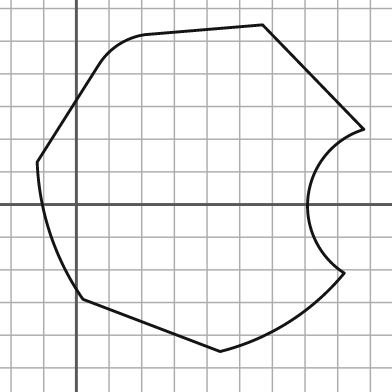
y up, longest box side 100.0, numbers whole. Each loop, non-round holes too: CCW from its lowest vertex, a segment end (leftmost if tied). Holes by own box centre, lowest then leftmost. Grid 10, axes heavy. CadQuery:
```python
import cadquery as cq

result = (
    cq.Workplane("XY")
    .moveTo(44.0, -45.0)
    .threePointArc((65.0, -36.0), (82.0, -21.0))
    .threePointArc((71.0, 3.0), (88.0, 23.0))
    .lineTo(57.0, 55.0)
    .lineTo(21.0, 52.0)
    .threePointArc((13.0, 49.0), (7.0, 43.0))
    .lineTo(-12.0, 13.0)
    .threePointArc((-8.0, -9.0), (2.0, -29.0))
    .close()
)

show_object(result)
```